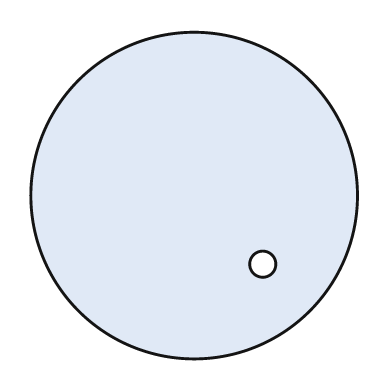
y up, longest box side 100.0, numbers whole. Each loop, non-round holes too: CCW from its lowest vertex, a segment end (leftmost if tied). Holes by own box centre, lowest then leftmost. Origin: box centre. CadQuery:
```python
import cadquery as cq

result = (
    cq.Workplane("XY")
    .moveTo(0.0, 0.0)
    .circle(50.0)
    .moveTo(21.0, -21.0)
    .circle(4.0)
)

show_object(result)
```